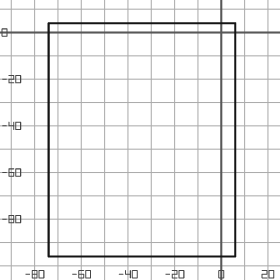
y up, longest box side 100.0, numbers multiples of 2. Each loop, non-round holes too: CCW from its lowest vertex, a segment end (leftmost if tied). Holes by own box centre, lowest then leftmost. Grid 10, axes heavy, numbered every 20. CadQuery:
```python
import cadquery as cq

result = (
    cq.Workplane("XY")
    .moveTo(-74.0, -96.0)
    .lineTo(6.0, -96.0)
    .lineTo(6.0, 4.0)
    .lineTo(-74.0, 4.0)
    .close()
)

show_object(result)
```